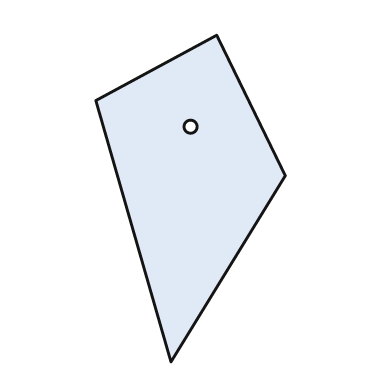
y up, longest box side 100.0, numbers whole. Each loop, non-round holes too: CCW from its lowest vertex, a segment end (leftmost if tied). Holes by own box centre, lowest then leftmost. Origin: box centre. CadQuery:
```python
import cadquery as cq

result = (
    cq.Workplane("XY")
    .moveTo(-6.0, -50.0)
    .lineTo(29.0, 7.0)
    .lineTo(8.0, 50.0)
    .lineTo(-29.0, 30.0)
    .close()
    .moveTo(0.0, 22.0)
    .circle(2.0)
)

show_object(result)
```